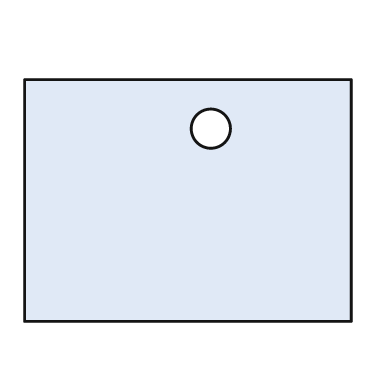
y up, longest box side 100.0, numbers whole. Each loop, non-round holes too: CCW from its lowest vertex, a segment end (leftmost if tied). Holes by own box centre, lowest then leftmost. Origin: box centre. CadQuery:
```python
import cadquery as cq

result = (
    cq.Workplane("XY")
    .moveTo(-50.0, -37.0)
    .lineTo(50.0, -37.0)
    .lineTo(50.0, 37.0)
    .lineTo(-50.0, 37.0)
    .close()
    .moveTo(7.0, 22.0)
    .circle(6.0)
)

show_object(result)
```